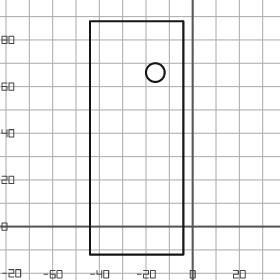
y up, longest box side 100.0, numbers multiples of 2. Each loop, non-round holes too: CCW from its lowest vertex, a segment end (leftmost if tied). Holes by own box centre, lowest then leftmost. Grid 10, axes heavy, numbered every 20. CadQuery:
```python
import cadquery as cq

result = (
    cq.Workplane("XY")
    .moveTo(-44.0, -12.0)
    .lineTo(-4.0, -12.0)
    .lineTo(-4.0, 88.0)
    .lineTo(-44.0, 88.0)
    .close()
    .moveTo(-16.0, 66.0)
    .circle(4.0)
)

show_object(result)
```